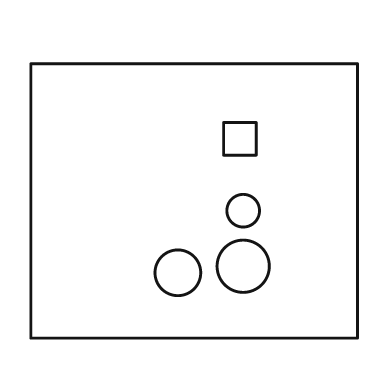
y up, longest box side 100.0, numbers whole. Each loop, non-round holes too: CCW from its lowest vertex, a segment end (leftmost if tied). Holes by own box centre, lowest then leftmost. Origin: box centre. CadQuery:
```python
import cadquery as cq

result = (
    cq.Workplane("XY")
    .moveTo(-50.0, -42.0)
    .lineTo(50.0, -42.0)
    .lineTo(50.0, 42.0)
    .lineTo(-50.0, 42.0)
    .close()
    .moveTo(-5.0, -22.0)
    .circle(7.0)
    .moveTo(15.0, -20.0)
    .circle(8.0)
    .moveTo(15.0, -3.0)
    .circle(5.0)
    .moveTo(9.0, 14.0)
    .lineTo(19.0, 14.0)
    .lineTo(19.0, 24.0)
    .lineTo(9.0, 24.0)
    .close()
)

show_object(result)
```